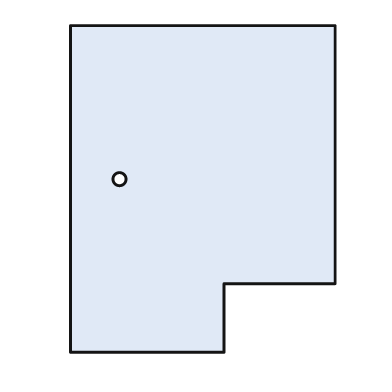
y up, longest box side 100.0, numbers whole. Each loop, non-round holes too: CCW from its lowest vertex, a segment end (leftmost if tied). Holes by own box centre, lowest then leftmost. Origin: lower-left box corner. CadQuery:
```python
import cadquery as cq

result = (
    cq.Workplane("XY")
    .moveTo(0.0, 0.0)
    .lineTo(47.0, 0.0)
    .lineTo(47.0, 21.0)
    .lineTo(81.0, 21.0)
    .lineTo(81.0, 100.0)
    .lineTo(0.0, 100.0)
    .close()
    .moveTo(15.0, 53.0)
    .circle(2.0)
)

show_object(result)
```